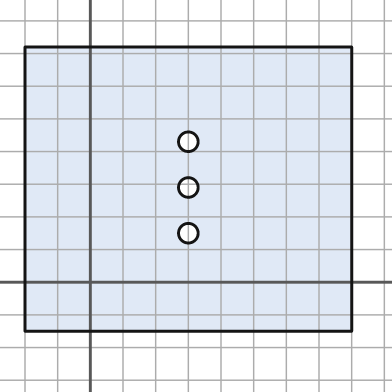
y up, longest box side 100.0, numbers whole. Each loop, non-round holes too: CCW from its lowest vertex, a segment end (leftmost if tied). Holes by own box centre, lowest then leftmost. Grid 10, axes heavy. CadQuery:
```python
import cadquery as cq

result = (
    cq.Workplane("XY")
    .moveTo(-20.0, -15.0)
    .lineTo(80.0, -15.0)
    .lineTo(80.0, 72.0)
    .lineTo(-20.0, 72.0)
    .close()
    .moveTo(30.0, 15.0)
    .circle(3.0)
    .moveTo(30.0, 29.0)
    .circle(3.0)
    .moveTo(30.0, 43.0)
    .circle(3.0)
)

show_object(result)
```